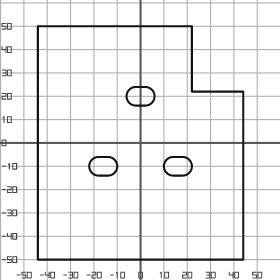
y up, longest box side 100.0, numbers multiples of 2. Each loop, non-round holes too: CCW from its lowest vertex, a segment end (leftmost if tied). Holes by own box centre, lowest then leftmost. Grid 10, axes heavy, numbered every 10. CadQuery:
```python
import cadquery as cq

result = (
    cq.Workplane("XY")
    .moveTo(-44.0, -50.0)
    .lineTo(44.0, -50.0)
    .lineTo(44.0, 22.0)
    .lineTo(22.0, 22.0)
    .lineTo(22.0, 50.0)
    .lineTo(-44.0, 50.0)
    .close()
    .moveTo(-18.0, -14.0)
    .lineTo(-14.0, -14.0)
    .threePointArc((-10.0, -10.0), (-14.0, -6.0))
    .lineTo(-18.0, -6.0)
    .threePointArc((-22.0, -10.0), (-18.0, -14.0))
    .close()
    .moveTo(14.0, -14.0)
    .lineTo(18.0, -14.0)
    .threePointArc((22.0, -10.0), (18.0, -6.0))
    .lineTo(14.0, -6.0)
    .threePointArc((10.0, -10.0), (14.0, -14.0))
    .close()
    .moveTo(-2.0, 16.0)
    .lineTo(2.0, 16.0)
    .threePointArc((6.0, 20.0), (2.0, 24.0))
    .lineTo(-2.0, 24.0)
    .threePointArc((-6.0, 20.0), (-2.0, 16.0))
    .close()
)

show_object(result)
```